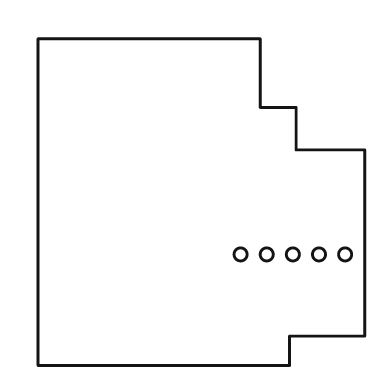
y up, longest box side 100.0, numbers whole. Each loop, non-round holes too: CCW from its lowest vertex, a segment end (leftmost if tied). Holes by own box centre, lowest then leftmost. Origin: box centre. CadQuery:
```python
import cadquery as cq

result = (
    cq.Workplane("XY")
    .moveTo(-50.0, -50.0)
    .lineTo(27.0, -50.0)
    .lineTo(27.0, -41.0)
    .lineTo(50.0, -41.0)
    .lineTo(50.0, 16.0)
    .lineTo(29.0, 16.0)
    .lineTo(29.0, 29.0)
    .lineTo(18.0, 29.0)
    .lineTo(18.0, 50.0)
    .lineTo(-50.0, 50.0)
    .close()
    .moveTo(12.0, -16.0)
    .circle(2.0)
    .moveTo(20.0, -16.0)
    .circle(2.0)
    .moveTo(28.0, -16.0)
    .circle(2.0)
    .moveTo(36.0, -16.0)
    .circle(2.0)
    .moveTo(44.0, -16.0)
    .circle(2.0)
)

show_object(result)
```